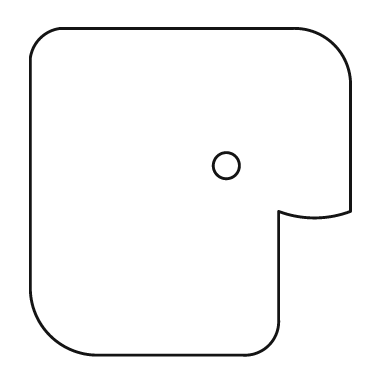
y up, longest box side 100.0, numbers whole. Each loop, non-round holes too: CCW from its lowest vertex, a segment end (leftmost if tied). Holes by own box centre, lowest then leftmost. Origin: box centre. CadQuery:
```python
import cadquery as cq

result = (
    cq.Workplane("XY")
    .moveTo(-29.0, -50.0)
    .lineTo(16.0, -50.0)
    .threePointArc((24.0, -47.0), (27.0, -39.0))
    .lineTo(27.0, -6.0)
    .threePointArc((38.0, -8.0), (49.0, -6.0))
    .lineTo(49.0, 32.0)
    .threePointArc((44.0, 45.0), (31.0, 50.0))
    .lineTo(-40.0, 50.0)
    .threePointArc((-46.0, 47.0), (-49.0, 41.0))
    .lineTo(-49.0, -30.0)
    .threePointArc((-43.0, -44.0), (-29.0, -50.0))
    .close()
    .moveTo(11.0, 8.0)
    .circle(4.0)
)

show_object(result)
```